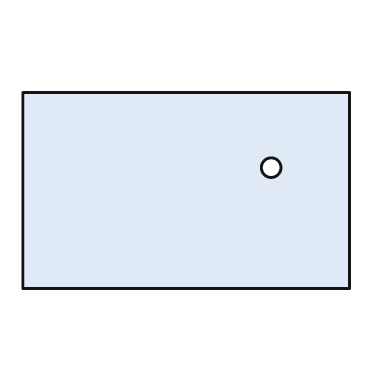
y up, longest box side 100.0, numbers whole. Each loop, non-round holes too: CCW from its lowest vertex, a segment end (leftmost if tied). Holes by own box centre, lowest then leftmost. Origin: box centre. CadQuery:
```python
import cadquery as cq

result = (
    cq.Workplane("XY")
    .moveTo(-50.0, -30.0)
    .lineTo(50.0, -30.0)
    .lineTo(50.0, 30.0)
    .lineTo(-50.0, 30.0)
    .close()
    .moveTo(26.0, 7.0)
    .circle(3.0)
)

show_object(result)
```